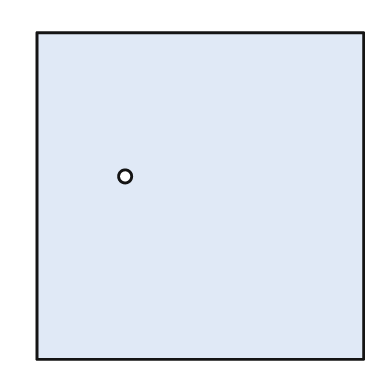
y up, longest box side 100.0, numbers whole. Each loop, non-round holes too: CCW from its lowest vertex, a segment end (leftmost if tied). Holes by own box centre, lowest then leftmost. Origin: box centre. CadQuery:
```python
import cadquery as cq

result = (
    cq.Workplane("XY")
    .moveTo(-50.0, -50.0)
    .lineTo(50.0, -50.0)
    .lineTo(50.0, 50.0)
    .lineTo(-50.0, 50.0)
    .close()
    .moveTo(-23.0, 6.0)
    .circle(2.0)
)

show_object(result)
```